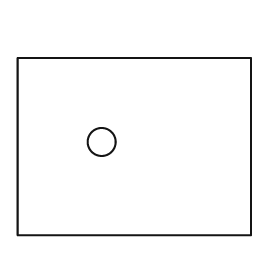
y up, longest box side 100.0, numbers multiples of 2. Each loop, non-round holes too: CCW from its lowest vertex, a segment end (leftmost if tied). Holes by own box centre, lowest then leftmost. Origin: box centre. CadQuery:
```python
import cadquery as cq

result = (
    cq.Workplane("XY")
    .moveTo(-50.0, -38.0)
    .lineTo(50.0, -38.0)
    .lineTo(50.0, 38.0)
    .lineTo(-50.0, 38.0)
    .close()
    .moveTo(-14.0, 2.0)
    .circle(6.0)
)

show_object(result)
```